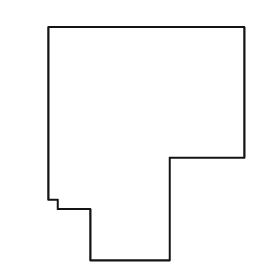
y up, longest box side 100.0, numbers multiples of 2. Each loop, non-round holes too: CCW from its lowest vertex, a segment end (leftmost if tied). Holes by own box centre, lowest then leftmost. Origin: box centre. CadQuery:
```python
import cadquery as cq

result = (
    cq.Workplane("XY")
    .moveTo(-24.0, -50.0)
    .lineTo(10.0, -50.0)
    .lineTo(10.0, -6.0)
    .lineTo(42.0, -6.0)
    .lineTo(42.0, 50.0)
    .lineTo(-42.0, 50.0)
    .lineTo(-42.0, -24.0)
    .lineTo(-38.0, -24.0)
    .lineTo(-38.0, -28.0)
    .lineTo(-24.0, -28.0)
    .close()
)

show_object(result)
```